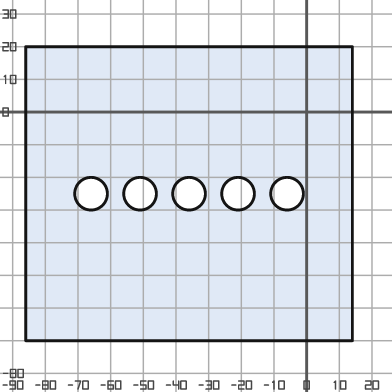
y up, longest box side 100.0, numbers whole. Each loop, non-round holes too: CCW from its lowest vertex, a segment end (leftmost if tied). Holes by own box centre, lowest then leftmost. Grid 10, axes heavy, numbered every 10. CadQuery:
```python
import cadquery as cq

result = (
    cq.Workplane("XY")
    .moveTo(-86.0, -70.0)
    .lineTo(14.0, -70.0)
    .lineTo(14.0, 20.0)
    .lineTo(-86.0, 20.0)
    .close()
    .moveTo(-66.0, -25.0)
    .circle(5.0)
    .moveTo(-51.0, -25.0)
    .circle(5.0)
    .moveTo(-36.0, -25.0)
    .circle(5.0)
    .moveTo(-21.0, -25.0)
    .circle(5.0)
    .moveTo(-6.0, -25.0)
    .circle(5.0)
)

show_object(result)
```